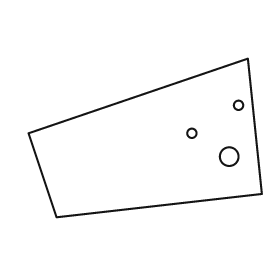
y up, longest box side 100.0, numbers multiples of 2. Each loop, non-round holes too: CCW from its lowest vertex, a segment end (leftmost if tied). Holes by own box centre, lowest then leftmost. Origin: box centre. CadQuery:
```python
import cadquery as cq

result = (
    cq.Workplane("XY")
    .moveTo(-38.0, -34.0)
    .lineTo(50.0, -24.0)
    .lineTo(44.0, 34.0)
    .lineTo(-50.0, 2.0)
    .close()
    .moveTo(36.0, -8.0)
    .circle(4.0)
    .moveTo(20.0, 2.0)
    .circle(2.0)
    .moveTo(40.0, 14.0)
    .circle(2.0)
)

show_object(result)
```